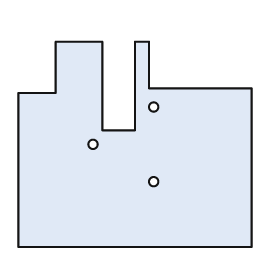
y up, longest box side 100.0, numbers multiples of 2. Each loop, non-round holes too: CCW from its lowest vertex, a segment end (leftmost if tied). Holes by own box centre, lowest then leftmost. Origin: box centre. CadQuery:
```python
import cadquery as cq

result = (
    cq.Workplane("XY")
    .moveTo(-50.0, -44.0)
    .lineTo(50.0, -44.0)
    .lineTo(50.0, 24.0)
    .lineTo(6.0, 24.0)
    .lineTo(6.0, 44.0)
    .lineTo(0.0, 44.0)
    .lineTo(0.0, 6.0)
    .lineTo(-14.0, 6.0)
    .lineTo(-14.0, 44.0)
    .lineTo(-34.0, 44.0)
    .lineTo(-34.0, 22.0)
    .lineTo(-50.0, 22.0)
    .close()
    .moveTo(8.0, -16.0)
    .circle(2.0)
    .moveTo(-18.0, 0.0)
    .circle(2.0)
    .moveTo(8.0, 16.0)
    .circle(2.0)
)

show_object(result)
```